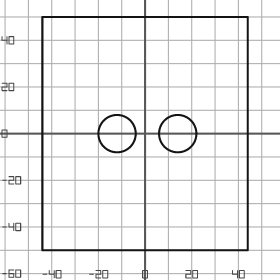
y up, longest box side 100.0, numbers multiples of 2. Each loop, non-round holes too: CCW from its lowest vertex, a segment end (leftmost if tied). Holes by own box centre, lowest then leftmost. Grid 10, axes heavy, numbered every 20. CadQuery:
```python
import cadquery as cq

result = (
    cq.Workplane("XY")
    .moveTo(-44.0, -50.0)
    .lineTo(44.0, -50.0)
    .lineTo(44.0, 50.0)
    .lineTo(-44.0, 50.0)
    .close()
    .moveTo(-12.0, 0.0)
    .circle(8.0)
    .moveTo(14.0, 0.0)
    .circle(8.0)
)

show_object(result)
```